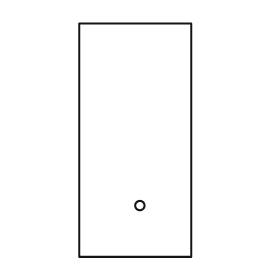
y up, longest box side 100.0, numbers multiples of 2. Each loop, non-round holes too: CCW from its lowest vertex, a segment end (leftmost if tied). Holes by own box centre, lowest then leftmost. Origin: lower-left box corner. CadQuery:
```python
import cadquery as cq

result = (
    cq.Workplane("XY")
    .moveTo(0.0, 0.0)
    .lineTo(48.0, 0.0)
    .lineTo(48.0, 100.0)
    .lineTo(0.0, 100.0)
    .close()
    .moveTo(26.0, 22.0)
    .circle(2.0)
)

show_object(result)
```